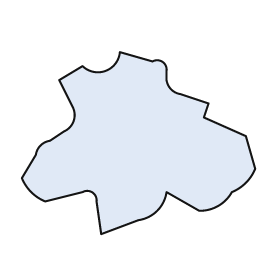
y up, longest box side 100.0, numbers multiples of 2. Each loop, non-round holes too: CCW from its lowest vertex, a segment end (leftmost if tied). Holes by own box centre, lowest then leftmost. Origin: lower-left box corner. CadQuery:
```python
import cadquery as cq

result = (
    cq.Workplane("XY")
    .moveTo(34.0, 0.0)
    .lineTo(50.0, 6.0)
    .threePointArc((58.0, 10.0), (62.0, 18.0))
    .lineTo(76.0, 10.0)
    .threePointArc((84.0, 12.0), (90.0, 18.0))
    .threePointArc((96.0, 22.0), (100.0, 28.0))
    .lineTo(96.0, 42.0)
    .lineTo(78.0, 50.0)
    .lineTo(80.0, 56.0)
    .lineTo(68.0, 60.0)
    .threePointArc((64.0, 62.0), (62.0, 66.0))
    .lineTo(62.0, 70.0)
    .threePointArc((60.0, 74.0), (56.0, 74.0))
    .lineTo(42.0, 78.0)
    .threePointArc((36.0, 70.0), (26.0, 72.0))
    .lineTo(16.0, 66.0)
    .lineTo(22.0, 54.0)
    .threePointArc((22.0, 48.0), (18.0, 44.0))
    .lineTo(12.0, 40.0)
    .threePointArc((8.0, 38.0), (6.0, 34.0))
    .lineTo(0.0, 24.0)
    .threePointArc((4.0, 18.0), (10.0, 14.0))
    .lineTo(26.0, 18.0)
    .threePointArc((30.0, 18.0), (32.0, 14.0))
    .close()
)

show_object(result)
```